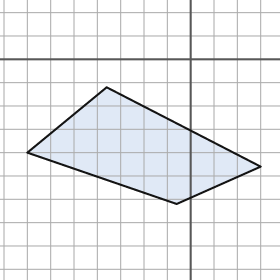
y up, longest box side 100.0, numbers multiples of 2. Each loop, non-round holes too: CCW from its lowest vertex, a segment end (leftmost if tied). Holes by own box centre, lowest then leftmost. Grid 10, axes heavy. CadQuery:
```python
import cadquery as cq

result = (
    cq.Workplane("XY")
    .moveTo(-6.0, -62.0)
    .lineTo(30.0, -46.0)
    .lineTo(-36.0, -12.0)
    .lineTo(-70.0, -40.0)
    .close()
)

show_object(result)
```